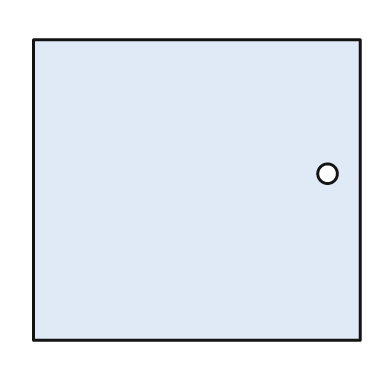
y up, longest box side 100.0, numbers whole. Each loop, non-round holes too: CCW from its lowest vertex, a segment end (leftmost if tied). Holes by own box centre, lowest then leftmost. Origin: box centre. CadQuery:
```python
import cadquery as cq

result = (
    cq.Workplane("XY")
    .moveTo(-50.0, -46.0)
    .lineTo(50.0, -46.0)
    .lineTo(50.0, 46.0)
    .lineTo(-50.0, 46.0)
    .close()
    .moveTo(40.0, 5.0)
    .circle(3.0)
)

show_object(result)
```